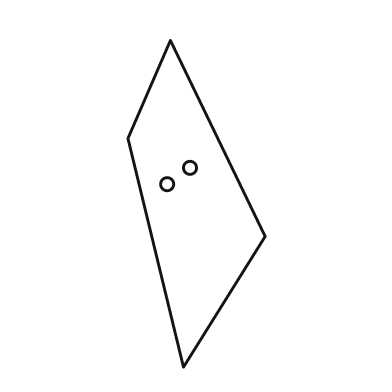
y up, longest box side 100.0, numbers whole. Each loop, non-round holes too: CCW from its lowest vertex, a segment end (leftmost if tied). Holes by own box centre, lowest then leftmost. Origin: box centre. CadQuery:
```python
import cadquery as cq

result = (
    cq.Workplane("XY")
    .moveTo(-4.0, -50.0)
    .lineTo(21.0, -10.0)
    .lineTo(-8.0, 50.0)
    .lineTo(-21.0, 20.0)
    .close()
    .moveTo(-9.0, 6.0)
    .circle(2.0)
    .moveTo(-2.0, 11.0)
    .circle(2.0)
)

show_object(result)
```